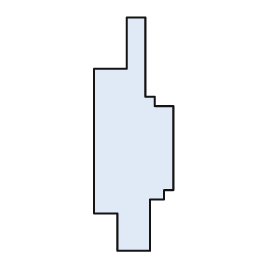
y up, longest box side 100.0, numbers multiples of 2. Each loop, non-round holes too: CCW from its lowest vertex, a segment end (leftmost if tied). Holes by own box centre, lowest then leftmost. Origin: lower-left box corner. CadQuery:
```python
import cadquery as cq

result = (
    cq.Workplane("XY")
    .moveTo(10.0, 0.0)
    .lineTo(24.0, 0.0)
    .lineTo(24.0, 22.0)
    .lineTo(30.0, 22.0)
    .lineTo(30.0, 26.0)
    .lineTo(34.0, 26.0)
    .lineTo(34.0, 62.0)
    .lineTo(26.0, 62.0)
    .lineTo(26.0, 66.0)
    .lineTo(22.0, 66.0)
    .lineTo(22.0, 100.0)
    .lineTo(14.0, 100.0)
    .lineTo(14.0, 78.0)
    .lineTo(0.0, 78.0)
    .lineTo(0.0, 16.0)
    .lineTo(10.0, 16.0)
    .close()
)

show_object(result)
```